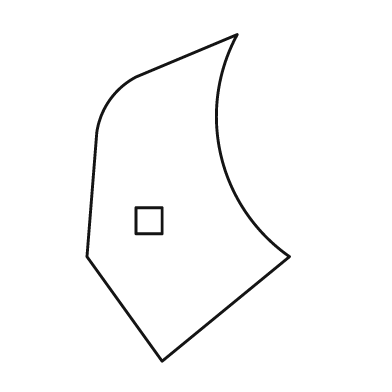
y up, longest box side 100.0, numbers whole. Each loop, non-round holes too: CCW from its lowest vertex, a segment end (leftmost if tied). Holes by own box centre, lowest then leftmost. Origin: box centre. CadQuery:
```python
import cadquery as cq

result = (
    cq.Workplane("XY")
    .moveTo(-8.0, -50.0)
    .lineTo(31.0, -18.0)
    .threePointArc((10.0, 13.0), (15.0, 50.0))
    .lineTo(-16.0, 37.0)
    .threePointArc((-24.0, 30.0), (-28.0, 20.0))
    .lineTo(-31.0, -18.0)
    .close()
    .moveTo(-16.0, -11.0)
    .lineTo(-8.0, -11.0)
    .lineTo(-8.0, -3.0)
    .lineTo(-16.0, -3.0)
    .close()
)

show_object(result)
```